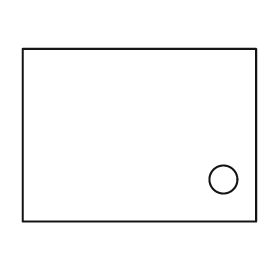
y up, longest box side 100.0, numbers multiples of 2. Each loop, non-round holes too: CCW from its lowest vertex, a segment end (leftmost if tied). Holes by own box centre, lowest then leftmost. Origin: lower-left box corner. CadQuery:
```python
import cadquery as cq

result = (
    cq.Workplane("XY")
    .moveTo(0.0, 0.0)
    .lineTo(100.0, 0.0)
    .lineTo(100.0, 74.0)
    .lineTo(0.0, 74.0)
    .close()
    .moveTo(86.0, 18.0)
    .circle(6.0)
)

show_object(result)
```